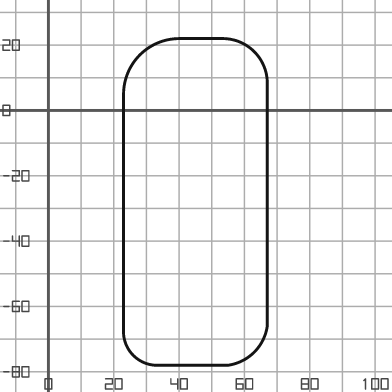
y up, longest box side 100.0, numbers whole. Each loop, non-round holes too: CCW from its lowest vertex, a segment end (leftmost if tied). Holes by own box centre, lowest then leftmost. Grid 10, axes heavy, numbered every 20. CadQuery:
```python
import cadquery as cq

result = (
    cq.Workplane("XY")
    .moveTo(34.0, -78.0)
    .lineTo(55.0, -78.0)
    .threePointArc((63.0, -74.0), (67.0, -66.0))
    .lineTo(67.0, 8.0)
    .threePointArc((63.0, 18.0), (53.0, 22.0))
    .lineTo(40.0, 22.0)
    .threePointArc((28.0, 17.0), (23.0, 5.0))
    .lineTo(23.0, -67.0)
    .threePointArc((26.0, -75.0), (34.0, -78.0))
    .close()
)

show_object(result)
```